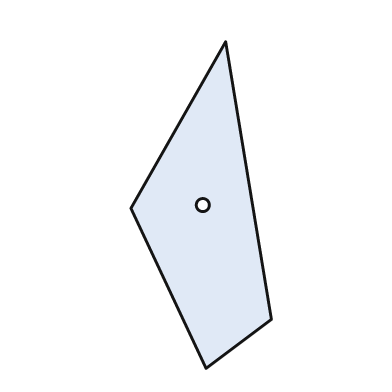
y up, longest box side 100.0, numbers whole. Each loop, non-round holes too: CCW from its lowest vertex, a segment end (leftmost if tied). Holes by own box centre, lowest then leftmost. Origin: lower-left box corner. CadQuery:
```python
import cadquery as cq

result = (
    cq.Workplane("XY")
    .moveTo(23.0, 0.0)
    .lineTo(43.0, 15.0)
    .lineTo(29.0, 100.0)
    .lineTo(0.0, 49.0)
    .close()
    .moveTo(22.0, 50.0)
    .circle(2.0)
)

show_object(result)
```